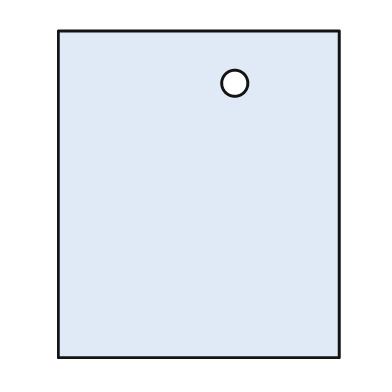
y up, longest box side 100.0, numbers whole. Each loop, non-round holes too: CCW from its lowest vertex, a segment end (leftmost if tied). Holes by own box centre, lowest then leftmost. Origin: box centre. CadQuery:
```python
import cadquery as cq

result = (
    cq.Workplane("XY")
    .moveTo(-43.0, -50.0)
    .lineTo(43.0, -50.0)
    .lineTo(43.0, 50.0)
    .lineTo(-43.0, 50.0)
    .close()
    .moveTo(11.0, 34.0)
    .circle(4.0)
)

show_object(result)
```